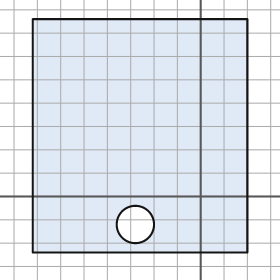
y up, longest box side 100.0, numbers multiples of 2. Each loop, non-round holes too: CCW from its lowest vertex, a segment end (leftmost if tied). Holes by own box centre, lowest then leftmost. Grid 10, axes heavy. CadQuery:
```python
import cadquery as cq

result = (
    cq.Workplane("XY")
    .moveTo(-72.0, -24.0)
    .lineTo(20.0, -24.0)
    .lineTo(20.0, 76.0)
    .lineTo(-72.0, 76.0)
    .close()
    .moveTo(-28.0, -12.0)
    .circle(8.0)
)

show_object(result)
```